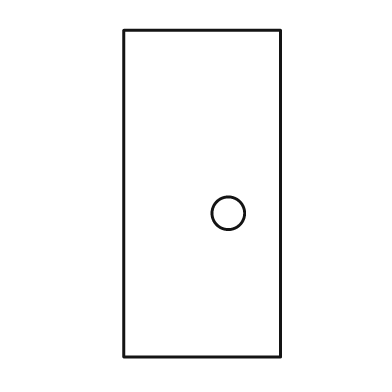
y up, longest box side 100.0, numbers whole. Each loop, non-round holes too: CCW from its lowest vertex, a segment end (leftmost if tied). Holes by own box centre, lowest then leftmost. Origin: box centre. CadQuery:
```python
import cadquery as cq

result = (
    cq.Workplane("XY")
    .moveTo(-24.0, -50.0)
    .lineTo(24.0, -50.0)
    .lineTo(24.0, 50.0)
    .lineTo(-24.0, 50.0)
    .close()
    .moveTo(8.0, -6.0)
    .circle(5.0)
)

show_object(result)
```